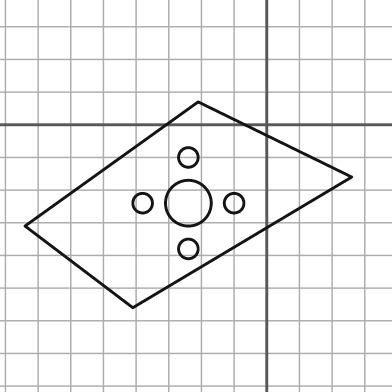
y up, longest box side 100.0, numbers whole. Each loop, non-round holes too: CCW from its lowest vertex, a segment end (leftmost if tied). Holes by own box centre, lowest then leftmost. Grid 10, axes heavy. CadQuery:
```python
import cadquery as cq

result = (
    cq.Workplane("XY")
    .moveTo(-41.0, -56.0)
    .lineTo(26.0, -16.0)
    .lineTo(-21.0, 7.0)
    .lineTo(-74.0, -31.0)
    .close()
    .moveTo(-24.0, -38.0)
    .circle(3.0)
    .moveTo(-38.0, -24.0)
    .circle(3.0)
    .moveTo(-24.0, -24.0)
    .circle(7.0)
    .moveTo(-10.0, -24.0)
    .circle(3.0)
    .moveTo(-24.0, -10.0)
    .circle(3.0)
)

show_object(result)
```